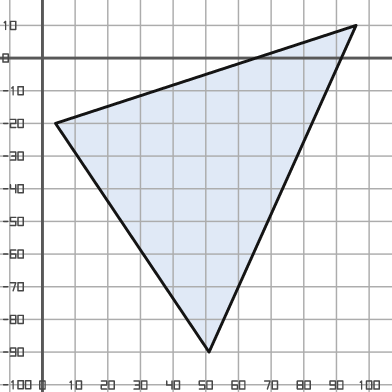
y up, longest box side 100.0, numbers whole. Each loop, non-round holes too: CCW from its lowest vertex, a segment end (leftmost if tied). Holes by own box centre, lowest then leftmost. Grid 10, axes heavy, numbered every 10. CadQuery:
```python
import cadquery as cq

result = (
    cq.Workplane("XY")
    .moveTo(51.0, -90.0)
    .lineTo(96.0, 10.0)
    .lineTo(4.0, -20.0)
    .close()
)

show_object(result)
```